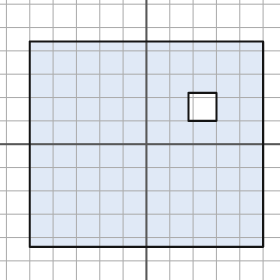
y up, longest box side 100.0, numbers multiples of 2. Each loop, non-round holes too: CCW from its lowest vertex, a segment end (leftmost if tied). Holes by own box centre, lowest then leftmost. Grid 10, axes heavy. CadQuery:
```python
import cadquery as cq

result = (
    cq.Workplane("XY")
    .moveTo(-50.0, -44.0)
    .lineTo(50.0, -44.0)
    .lineTo(50.0, 44.0)
    .lineTo(-50.0, 44.0)
    .close()
    .moveTo(18.0, 10.0)
    .lineTo(30.0, 10.0)
    .lineTo(30.0, 22.0)
    .lineTo(18.0, 22.0)
    .close()
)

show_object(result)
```